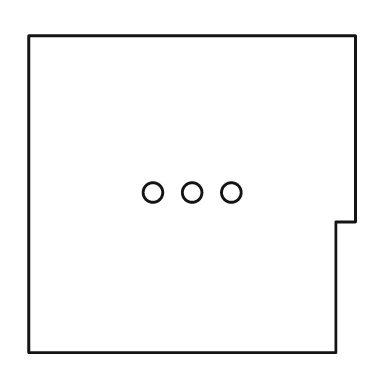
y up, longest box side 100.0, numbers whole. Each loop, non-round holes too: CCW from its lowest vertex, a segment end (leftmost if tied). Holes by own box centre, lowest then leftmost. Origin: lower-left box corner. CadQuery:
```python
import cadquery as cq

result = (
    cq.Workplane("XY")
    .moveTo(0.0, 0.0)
    .lineTo(94.0, 0.0)
    .lineTo(94.0, 40.0)
    .lineTo(100.0, 40.0)
    .lineTo(100.0, 97.0)
    .lineTo(0.0, 97.0)
    .close()
    .moveTo(38.0, 49.0)
    .circle(3.0)
    .moveTo(50.0, 49.0)
    .circle(3.0)
    .moveTo(62.0, 49.0)
    .circle(3.0)
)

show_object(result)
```